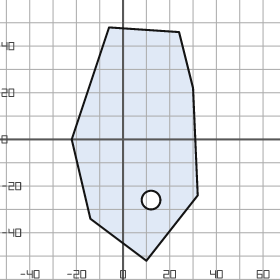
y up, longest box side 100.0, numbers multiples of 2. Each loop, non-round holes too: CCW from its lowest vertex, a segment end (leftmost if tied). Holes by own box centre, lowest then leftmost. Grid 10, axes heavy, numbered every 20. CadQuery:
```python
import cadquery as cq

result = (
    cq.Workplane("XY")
    .moveTo(10.0, -52.0)
    .lineTo(32.0, -24.0)
    .lineTo(30.0, 22.0)
    .lineTo(24.0, 46.0)
    .lineTo(-6.0, 48.0)
    .lineTo(-22.0, 0.0)
    .lineTo(-14.0, -34.0)
    .close()
    .moveTo(12.0, -26.0)
    .circle(4.0)
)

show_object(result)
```